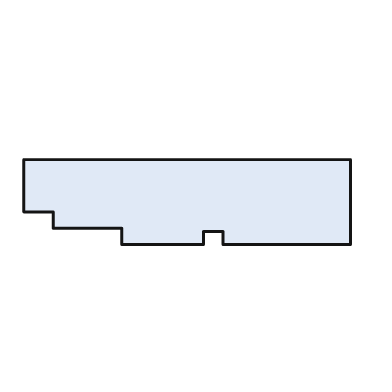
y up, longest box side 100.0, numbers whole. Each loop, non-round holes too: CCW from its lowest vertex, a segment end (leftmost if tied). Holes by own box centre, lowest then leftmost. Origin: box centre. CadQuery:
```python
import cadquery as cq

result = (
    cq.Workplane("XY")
    .moveTo(-20.0, -13.0)
    .lineTo(5.0, -13.0)
    .lineTo(5.0, -9.0)
    .lineTo(11.0, -9.0)
    .lineTo(11.0, -13.0)
    .lineTo(50.0, -13.0)
    .lineTo(50.0, 13.0)
    .lineTo(-50.0, 13.0)
    .lineTo(-50.0, -3.0)
    .lineTo(-41.0, -3.0)
    .lineTo(-41.0, -8.0)
    .lineTo(-20.0, -8.0)
    .close()
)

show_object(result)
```